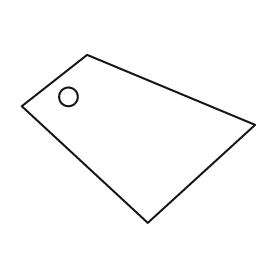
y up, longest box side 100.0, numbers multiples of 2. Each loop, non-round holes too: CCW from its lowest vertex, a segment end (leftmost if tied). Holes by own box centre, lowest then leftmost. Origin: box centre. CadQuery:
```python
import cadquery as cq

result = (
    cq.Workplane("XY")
    .moveTo(4.0, -36.0)
    .lineTo(50.0, 6.0)
    .lineTo(-22.0, 36.0)
    .lineTo(-50.0, 14.0)
    .close()
    .moveTo(-30.0, 18.0)
    .circle(4.0)
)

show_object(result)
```